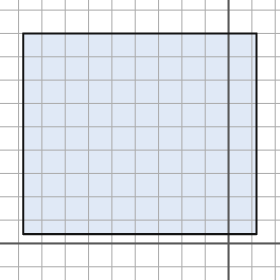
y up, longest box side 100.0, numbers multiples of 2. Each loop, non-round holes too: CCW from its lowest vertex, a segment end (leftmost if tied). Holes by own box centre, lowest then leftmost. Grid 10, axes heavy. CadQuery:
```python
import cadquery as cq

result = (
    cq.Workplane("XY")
    .moveTo(-88.0, 4.0)
    .lineTo(12.0, 4.0)
    .lineTo(12.0, 90.0)
    .lineTo(-88.0, 90.0)
    .close()
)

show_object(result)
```